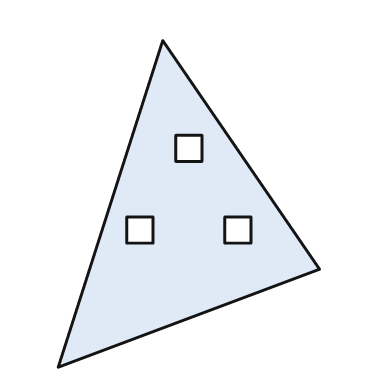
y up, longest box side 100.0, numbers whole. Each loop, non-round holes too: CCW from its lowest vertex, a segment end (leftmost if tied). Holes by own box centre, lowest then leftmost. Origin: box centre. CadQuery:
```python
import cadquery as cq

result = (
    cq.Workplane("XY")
    .moveTo(-40.0, -50.0)
    .lineTo(40.0, -20.0)
    .lineTo(-8.0, 50.0)
    .close()
    .moveTo(-19.0, -12.0)
    .lineTo(-11.0, -12.0)
    .lineTo(-11.0, -4.0)
    .lineTo(-19.0, -4.0)
    .close()
    .moveTo(11.0, -12.0)
    .lineTo(19.0, -12.0)
    .lineTo(19.0, -4.0)
    .lineTo(11.0, -4.0)
    .close()
    .moveTo(-4.0, 13.0)
    .lineTo(4.0, 13.0)
    .lineTo(4.0, 21.0)
    .lineTo(-4.0, 21.0)
    .close()
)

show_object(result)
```